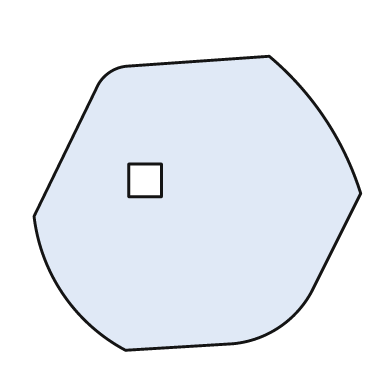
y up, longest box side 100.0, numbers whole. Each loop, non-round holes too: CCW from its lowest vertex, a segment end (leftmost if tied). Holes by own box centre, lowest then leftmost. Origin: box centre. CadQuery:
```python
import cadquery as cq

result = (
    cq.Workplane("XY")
    .moveTo(-22.0, -45.0)
    .lineTo(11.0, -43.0)
    .threePointArc((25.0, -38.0), (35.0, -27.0))
    .lineTo(50.0, 3.0)
    .threePointArc((39.0, 26.0), (22.0, 45.0))
    .lineTo(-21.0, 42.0)
    .threePointArc((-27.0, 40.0), (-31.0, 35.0))
    .lineTo(-50.0, -4.0)
    .threePointArc((-41.0, -28.0), (-22.0, -45.0))
    .close()
    .moveTo(-21.0, 2.0)
    .lineTo(-11.0, 2.0)
    .lineTo(-11.0, 12.0)
    .lineTo(-21.0, 12.0)
    .close()
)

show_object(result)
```